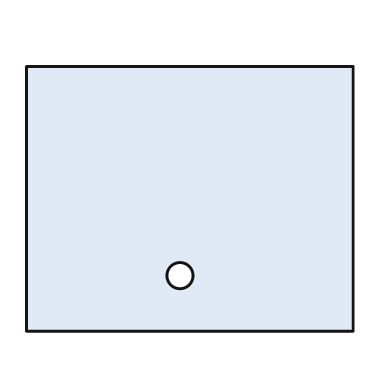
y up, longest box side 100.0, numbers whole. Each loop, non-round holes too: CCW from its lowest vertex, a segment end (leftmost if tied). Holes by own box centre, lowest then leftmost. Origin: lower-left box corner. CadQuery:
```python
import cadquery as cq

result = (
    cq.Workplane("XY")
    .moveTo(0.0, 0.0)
    .lineTo(100.0, 0.0)
    .lineTo(100.0, 81.0)
    .lineTo(0.0, 81.0)
    .close()
    .moveTo(47.0, 17.0)
    .circle(4.0)
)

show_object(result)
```